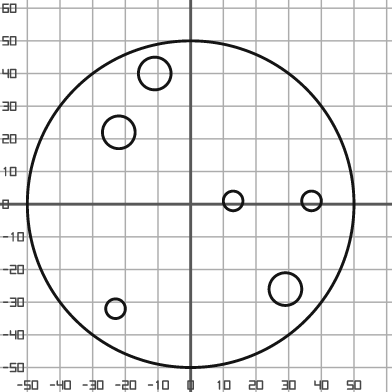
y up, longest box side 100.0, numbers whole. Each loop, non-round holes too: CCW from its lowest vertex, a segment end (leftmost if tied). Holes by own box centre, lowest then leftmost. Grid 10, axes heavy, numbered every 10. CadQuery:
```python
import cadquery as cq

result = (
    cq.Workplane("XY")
    .moveTo(0.0, 0.0)
    .circle(50.0)
    .moveTo(-23.0, -32.0)
    .circle(3.0)
    .moveTo(29.0, -26.0)
    .circle(5.0)
    .moveTo(13.0, 1.0)
    .circle(3.0)
    .moveTo(37.0, 1.0)
    .circle(3.0)
    .moveTo(-22.0, 22.0)
    .circle(5.0)
    .moveTo(-11.0, 40.0)
    .circle(5.0)
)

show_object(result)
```